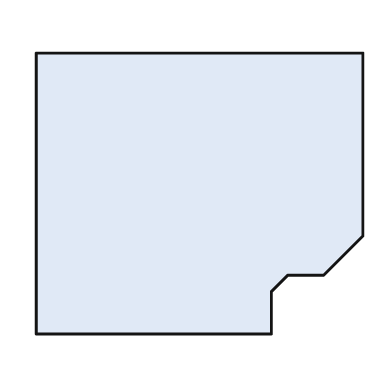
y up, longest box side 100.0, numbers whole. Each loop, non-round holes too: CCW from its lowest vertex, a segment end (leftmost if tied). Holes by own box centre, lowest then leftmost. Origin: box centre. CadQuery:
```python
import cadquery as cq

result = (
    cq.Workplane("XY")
    .moveTo(-50.0, -43.0)
    .lineTo(22.0, -43.0)
    .lineTo(22.0, -30.0)
    .lineTo(27.0, -25.0)
    .lineTo(38.0, -25.0)
    .lineTo(50.0, -13.0)
    .lineTo(50.0, 43.0)
    .lineTo(-50.0, 43.0)
    .close()
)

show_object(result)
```